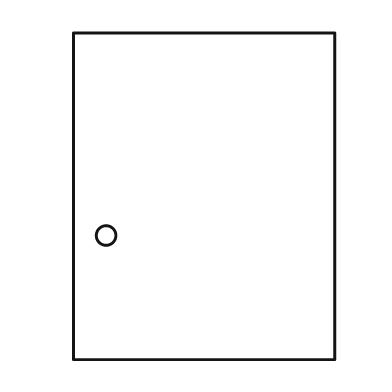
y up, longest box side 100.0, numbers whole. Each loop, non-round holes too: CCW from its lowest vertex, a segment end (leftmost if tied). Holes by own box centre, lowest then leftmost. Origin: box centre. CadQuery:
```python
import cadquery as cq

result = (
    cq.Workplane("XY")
    .moveTo(-40.0, -50.0)
    .lineTo(40.0, -50.0)
    .lineTo(40.0, 50.0)
    .lineTo(-40.0, 50.0)
    .close()
    .moveTo(-30.0, -12.0)
    .circle(3.0)
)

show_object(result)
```